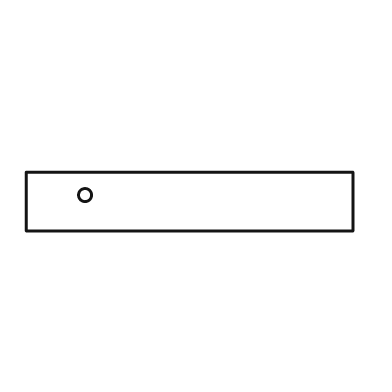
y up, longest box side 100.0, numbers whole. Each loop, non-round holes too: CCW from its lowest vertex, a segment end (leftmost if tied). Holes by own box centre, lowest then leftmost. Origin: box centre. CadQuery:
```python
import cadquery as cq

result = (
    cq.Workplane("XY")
    .moveTo(-50.0, -9.0)
    .lineTo(50.0, -9.0)
    .lineTo(50.0, 9.0)
    .lineTo(-50.0, 9.0)
    .close()
    .moveTo(-32.0, 2.0)
    .circle(2.0)
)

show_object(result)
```